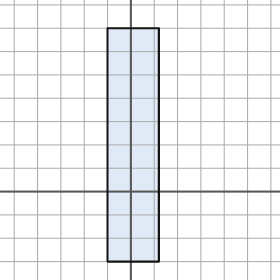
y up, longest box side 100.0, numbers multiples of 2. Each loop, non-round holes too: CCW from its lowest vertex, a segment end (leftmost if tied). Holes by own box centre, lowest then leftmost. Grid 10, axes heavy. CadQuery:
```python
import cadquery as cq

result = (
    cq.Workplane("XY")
    .moveTo(-10.0, -30.0)
    .lineTo(12.0, -30.0)
    .lineTo(12.0, 70.0)
    .lineTo(-10.0, 70.0)
    .close()
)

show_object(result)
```